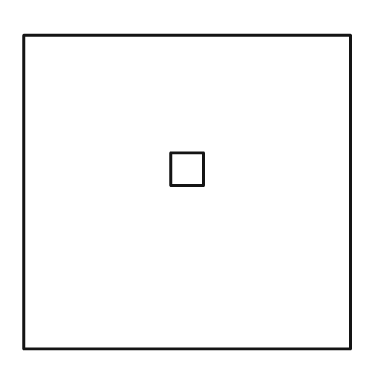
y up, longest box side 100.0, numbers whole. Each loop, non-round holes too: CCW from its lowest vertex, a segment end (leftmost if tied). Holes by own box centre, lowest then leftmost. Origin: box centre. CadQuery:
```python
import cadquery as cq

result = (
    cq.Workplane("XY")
    .moveTo(-50.0, -48.0)
    .lineTo(50.0, -48.0)
    .lineTo(50.0, 48.0)
    .lineTo(-50.0, 48.0)
    .close()
    .moveTo(-5.0, 2.0)
    .lineTo(5.0, 2.0)
    .lineTo(5.0, 12.0)
    .lineTo(-5.0, 12.0)
    .close()
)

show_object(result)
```